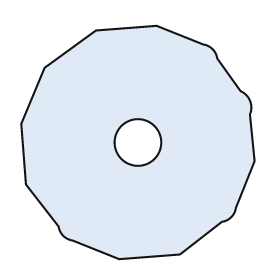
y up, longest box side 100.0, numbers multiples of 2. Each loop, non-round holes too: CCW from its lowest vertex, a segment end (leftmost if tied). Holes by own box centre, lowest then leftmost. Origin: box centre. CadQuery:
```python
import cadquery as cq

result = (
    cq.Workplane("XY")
    .moveTo(-8.0, -50.0)
    .lineTo(18.0, -48.0)
    .lineTo(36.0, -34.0)
    .threePointArc((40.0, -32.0), (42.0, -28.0))
    .lineTo(50.0, -8.0)
    .lineTo(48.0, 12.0)
    .threePointArc((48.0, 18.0), (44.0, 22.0))
    .lineTo(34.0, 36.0)
    .threePointArc((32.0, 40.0), (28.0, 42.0))
    .lineTo(8.0, 50.0)
    .lineTo(-18.0, 48.0)
    .lineTo(-40.0, 32.0)
    .lineTo(-50.0, 8.0)
    .lineTo(-48.0, -18.0)
    .lineTo(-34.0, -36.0)
    .threePointArc((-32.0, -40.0), (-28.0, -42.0))
    .close()
    .moveTo(0.0, 0.0)
    .circle(10.0)
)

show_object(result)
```